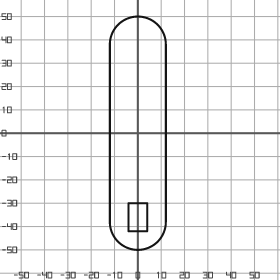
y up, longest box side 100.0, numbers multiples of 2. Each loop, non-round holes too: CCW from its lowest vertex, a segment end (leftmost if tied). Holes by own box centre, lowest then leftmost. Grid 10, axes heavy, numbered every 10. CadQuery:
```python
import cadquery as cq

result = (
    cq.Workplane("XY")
    .moveTo(-12.0, -38.0)
    .threePointArc((0.0, -50.0), (12.0, -38.0))
    .lineTo(12.0, 38.0)
    .threePointArc((0.0, 50.0), (-12.0, 38.0))
    .close()
    .moveTo(-4.0, -42.0)
    .lineTo(4.0, -42.0)
    .lineTo(4.0, -30.0)
    .lineTo(-4.0, -30.0)
    .close()
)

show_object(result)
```